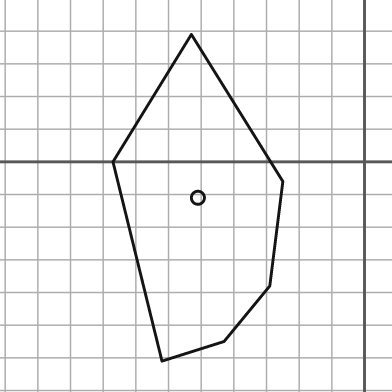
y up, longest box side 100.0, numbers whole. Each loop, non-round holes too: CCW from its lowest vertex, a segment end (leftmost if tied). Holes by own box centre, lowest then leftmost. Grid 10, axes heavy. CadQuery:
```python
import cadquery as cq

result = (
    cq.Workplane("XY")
    .moveTo(-62.0, -61.0)
    .lineTo(-43.0, -55.0)
    .lineTo(-29.0, -38.0)
    .lineTo(-25.0, -6.0)
    .lineTo(-53.0, 39.0)
    .lineTo(-77.0, 0.0)
    .close()
    .moveTo(-51.0, -11.0)
    .circle(2.0)
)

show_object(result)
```